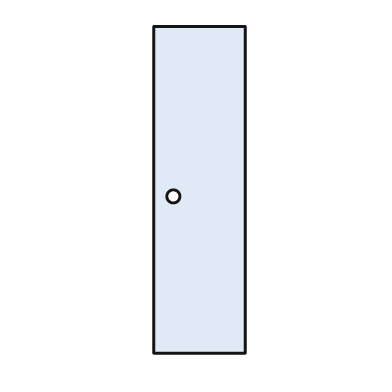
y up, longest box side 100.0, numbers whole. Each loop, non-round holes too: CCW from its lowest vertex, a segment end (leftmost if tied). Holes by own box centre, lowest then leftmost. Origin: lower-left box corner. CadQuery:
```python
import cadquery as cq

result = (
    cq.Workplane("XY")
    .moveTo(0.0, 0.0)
    .lineTo(28.0, 0.0)
    .lineTo(28.0, 100.0)
    .lineTo(0.0, 100.0)
    .close()
    .moveTo(6.0, 48.0)
    .circle(2.0)
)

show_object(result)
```